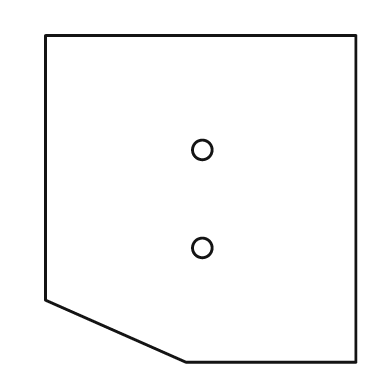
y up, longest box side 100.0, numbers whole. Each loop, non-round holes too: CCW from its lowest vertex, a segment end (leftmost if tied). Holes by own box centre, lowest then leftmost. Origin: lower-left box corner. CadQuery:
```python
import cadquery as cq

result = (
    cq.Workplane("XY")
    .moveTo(43.0, 0.0)
    .lineTo(95.0, 0.0)
    .lineTo(95.0, 100.0)
    .lineTo(0.0, 100.0)
    .lineTo(0.0, 19.0)
    .close()
    .moveTo(48.0, 35.0)
    .circle(3.0)
    .moveTo(48.0, 65.0)
    .circle(3.0)
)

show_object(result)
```